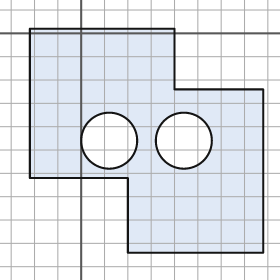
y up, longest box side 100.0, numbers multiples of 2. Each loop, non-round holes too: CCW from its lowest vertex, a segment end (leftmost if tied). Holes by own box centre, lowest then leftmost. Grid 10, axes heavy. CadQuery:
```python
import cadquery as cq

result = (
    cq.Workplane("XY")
    .moveTo(20.0, -94.0)
    .lineTo(78.0, -94.0)
    .lineTo(78.0, -24.0)
    .lineTo(40.0, -24.0)
    .lineTo(40.0, 2.0)
    .lineTo(-22.0, 2.0)
    .lineTo(-22.0, -62.0)
    .lineTo(20.0, -62.0)
    .close()
    .moveTo(12.0, -46.0)
    .circle(12.0)
    .moveTo(44.0, -46.0)
    .circle(12.0)
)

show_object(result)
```